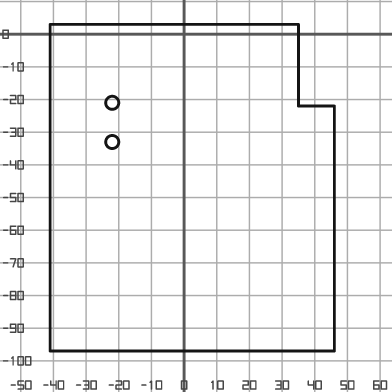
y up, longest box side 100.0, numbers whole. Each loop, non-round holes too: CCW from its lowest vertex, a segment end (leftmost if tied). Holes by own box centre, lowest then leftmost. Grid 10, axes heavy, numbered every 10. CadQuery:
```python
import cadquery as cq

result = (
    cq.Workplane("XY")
    .moveTo(-41.0, -97.0)
    .lineTo(46.0, -97.0)
    .lineTo(46.0, -22.0)
    .lineTo(35.0, -22.0)
    .lineTo(35.0, 3.0)
    .lineTo(-41.0, 3.0)
    .close()
    .moveTo(-22.0, -33.0)
    .circle(2.0)
    .moveTo(-22.0, -21.0)
    .circle(2.0)
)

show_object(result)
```